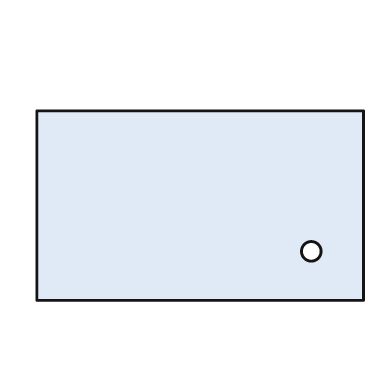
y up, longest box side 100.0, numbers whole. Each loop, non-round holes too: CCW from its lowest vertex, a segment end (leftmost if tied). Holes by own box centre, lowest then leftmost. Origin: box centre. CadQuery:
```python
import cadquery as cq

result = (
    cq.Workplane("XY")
    .moveTo(-50.0, -29.0)
    .lineTo(50.0, -29.0)
    .lineTo(50.0, 29.0)
    .lineTo(-50.0, 29.0)
    .close()
    .moveTo(34.0, -14.0)
    .circle(3.0)
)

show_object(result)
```